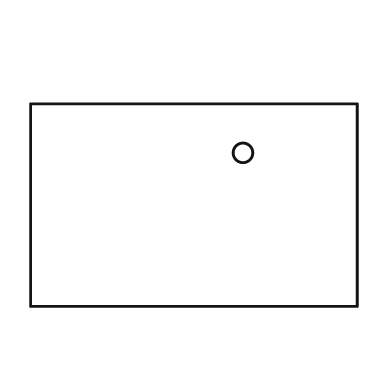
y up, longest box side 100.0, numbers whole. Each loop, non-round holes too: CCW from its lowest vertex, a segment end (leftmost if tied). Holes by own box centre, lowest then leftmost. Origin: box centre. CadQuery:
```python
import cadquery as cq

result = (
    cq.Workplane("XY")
    .moveTo(-50.0, -31.0)
    .lineTo(50.0, -31.0)
    .lineTo(50.0, 31.0)
    .lineTo(-50.0, 31.0)
    .close()
    .moveTo(15.0, 16.0)
    .circle(3.0)
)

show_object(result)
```